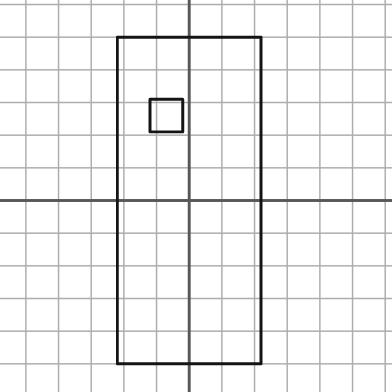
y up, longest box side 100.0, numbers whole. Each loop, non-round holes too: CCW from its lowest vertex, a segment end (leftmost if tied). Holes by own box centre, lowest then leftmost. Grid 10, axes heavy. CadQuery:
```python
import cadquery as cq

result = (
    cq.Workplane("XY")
    .moveTo(-22.0, -50.0)
    .lineTo(22.0, -50.0)
    .lineTo(22.0, 50.0)
    .lineTo(-22.0, 50.0)
    .close()
    .moveTo(-12.0, 21.0)
    .lineTo(-2.0, 21.0)
    .lineTo(-2.0, 31.0)
    .lineTo(-12.0, 31.0)
    .close()
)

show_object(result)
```